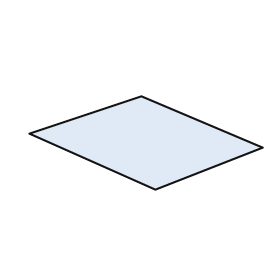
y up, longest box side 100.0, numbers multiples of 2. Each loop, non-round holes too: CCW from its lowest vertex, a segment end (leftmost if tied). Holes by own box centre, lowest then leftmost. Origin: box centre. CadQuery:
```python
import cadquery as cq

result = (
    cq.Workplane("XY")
    .moveTo(4.0, -20.0)
    .lineTo(50.0, -2.0)
    .lineTo(-2.0, 20.0)
    .lineTo(-50.0, 4.0)
    .close()
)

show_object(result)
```